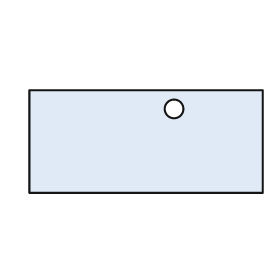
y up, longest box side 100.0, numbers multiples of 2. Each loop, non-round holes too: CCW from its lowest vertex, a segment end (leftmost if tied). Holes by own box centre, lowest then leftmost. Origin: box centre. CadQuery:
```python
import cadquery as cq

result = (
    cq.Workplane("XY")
    .moveTo(-50.0, -22.0)
    .lineTo(50.0, -22.0)
    .lineTo(50.0, 22.0)
    .lineTo(-50.0, 22.0)
    .close()
    .moveTo(12.0, 14.0)
    .circle(4.0)
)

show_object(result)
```